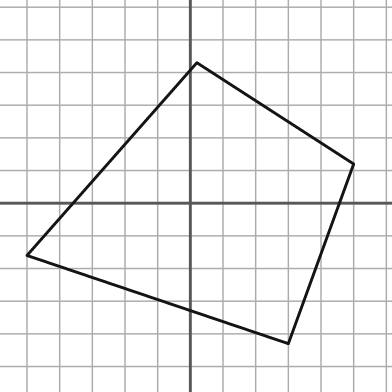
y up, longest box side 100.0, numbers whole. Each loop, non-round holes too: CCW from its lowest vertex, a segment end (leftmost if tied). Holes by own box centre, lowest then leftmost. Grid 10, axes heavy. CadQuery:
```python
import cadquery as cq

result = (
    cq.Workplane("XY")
    .moveTo(30.0, -43.0)
    .lineTo(50.0, 12.0)
    .lineTo(2.0, 43.0)
    .lineTo(-50.0, -16.0)
    .close()
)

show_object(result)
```